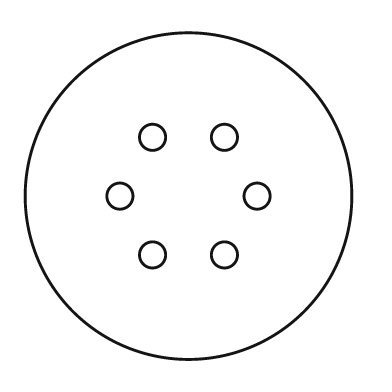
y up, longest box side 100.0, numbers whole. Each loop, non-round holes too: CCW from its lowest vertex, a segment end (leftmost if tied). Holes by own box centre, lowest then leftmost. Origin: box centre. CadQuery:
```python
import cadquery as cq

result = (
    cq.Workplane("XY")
    .moveTo(0.0, 0.0)
    .circle(50.0)
    .moveTo(-11.0, -18.0)
    .circle(4.0)
    .moveTo(11.0, -18.0)
    .circle(4.0)
    .moveTo(-21.0, 0.0)
    .circle(4.0)
    .moveTo(21.0, 0.0)
    .circle(4.0)
    .moveTo(-11.0, 18.0)
    .circle(4.0)
    .moveTo(11.0, 18.0)
    .circle(4.0)
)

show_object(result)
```